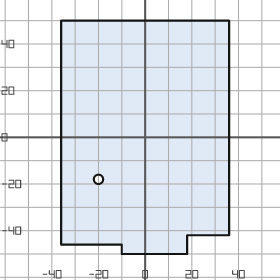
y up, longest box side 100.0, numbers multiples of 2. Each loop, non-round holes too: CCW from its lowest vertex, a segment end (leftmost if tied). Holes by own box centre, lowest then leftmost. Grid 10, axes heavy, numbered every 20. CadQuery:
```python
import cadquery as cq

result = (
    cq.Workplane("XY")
    .moveTo(-10.0, -50.0)
    .lineTo(18.0, -50.0)
    .lineTo(18.0, -42.0)
    .lineTo(36.0, -42.0)
    .lineTo(36.0, 50.0)
    .lineTo(-36.0, 50.0)
    .lineTo(-36.0, -46.0)
    .lineTo(-10.0, -46.0)
    .close()
    .moveTo(-20.0, -18.0)
    .circle(2.0)
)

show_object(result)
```